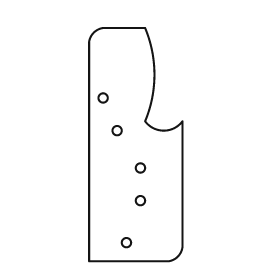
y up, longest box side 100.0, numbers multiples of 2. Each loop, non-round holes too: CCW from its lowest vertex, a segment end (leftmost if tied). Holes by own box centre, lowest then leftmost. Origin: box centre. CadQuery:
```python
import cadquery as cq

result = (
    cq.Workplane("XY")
    .moveTo(-20.0, -50.0)
    .lineTo(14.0, -50.0)
    .threePointArc((18.0, -48.0), (20.0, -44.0))
    .lineTo(20.0, 10.0)
    .threePointArc((12.0, 6.0), (4.0, 10.0))
    .threePointArc((8.0, 30.0), (4.0, 50.0))
    .lineTo(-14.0, 50.0)
    .threePointArc((-18.0, 48.0), (-20.0, 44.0))
    .close()
    .moveTo(-4.0, -42.0)
    .circle(2.0)
    .moveTo(2.0, -24.0)
    .circle(2.0)
    .moveTo(2.0, -10.0)
    .circle(2.0)
    .moveTo(-8.0, 6.0)
    .circle(2.0)
    .moveTo(-14.0, 20.0)
    .circle(2.0)
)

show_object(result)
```